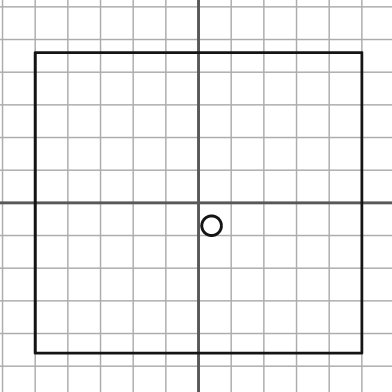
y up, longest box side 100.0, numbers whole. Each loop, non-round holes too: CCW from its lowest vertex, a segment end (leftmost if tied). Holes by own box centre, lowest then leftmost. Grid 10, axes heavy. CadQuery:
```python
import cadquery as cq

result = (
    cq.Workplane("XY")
    .moveTo(-50.0, -46.0)
    .lineTo(50.0, -46.0)
    .lineTo(50.0, 46.0)
    .lineTo(-50.0, 46.0)
    .close()
    .moveTo(4.0, -7.0)
    .circle(3.0)
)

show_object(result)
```